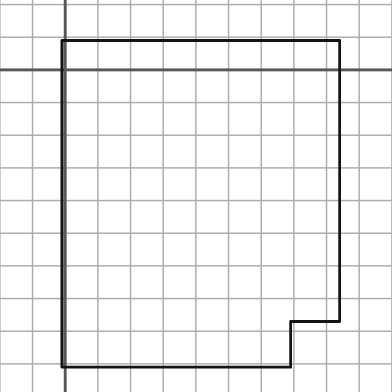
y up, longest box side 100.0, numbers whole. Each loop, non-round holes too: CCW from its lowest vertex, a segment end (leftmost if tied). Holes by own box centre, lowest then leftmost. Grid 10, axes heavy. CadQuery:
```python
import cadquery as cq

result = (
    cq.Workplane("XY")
    .moveTo(-1.0, -91.0)
    .lineTo(69.0, -91.0)
    .lineTo(69.0, -77.0)
    .lineTo(84.0, -77.0)
    .lineTo(84.0, 9.0)
    .lineTo(-1.0, 9.0)
    .close()
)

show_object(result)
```